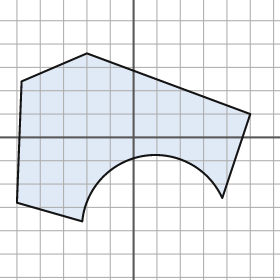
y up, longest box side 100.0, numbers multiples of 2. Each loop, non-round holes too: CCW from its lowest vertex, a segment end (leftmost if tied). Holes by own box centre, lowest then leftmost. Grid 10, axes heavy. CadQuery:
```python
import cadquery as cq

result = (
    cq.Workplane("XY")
    .moveTo(-22.0, -36.0)
    .threePointArc((4.0, -8.0), (38.0, -26.0))
    .lineTo(50.0, 10.0)
    .lineTo(-20.0, 36.0)
    .lineTo(-48.0, 24.0)
    .lineTo(-50.0, -28.0)
    .close()
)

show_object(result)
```